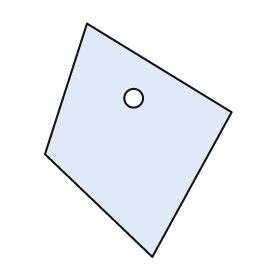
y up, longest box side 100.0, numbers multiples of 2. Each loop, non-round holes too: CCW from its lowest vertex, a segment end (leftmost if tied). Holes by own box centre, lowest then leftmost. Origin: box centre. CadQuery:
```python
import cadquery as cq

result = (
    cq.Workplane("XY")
    .moveTo(6.0, -50.0)
    .lineTo(40.0, 12.0)
    .lineTo(-22.0, 50.0)
    .lineTo(-40.0, -6.0)
    .close()
    .moveTo(-2.0, 18.0)
    .circle(4.0)
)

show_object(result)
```